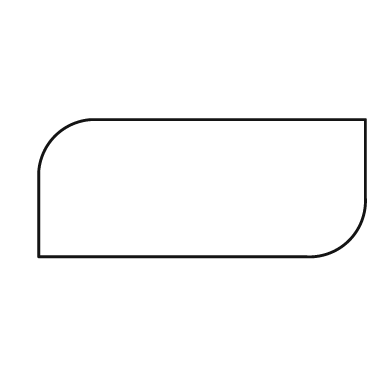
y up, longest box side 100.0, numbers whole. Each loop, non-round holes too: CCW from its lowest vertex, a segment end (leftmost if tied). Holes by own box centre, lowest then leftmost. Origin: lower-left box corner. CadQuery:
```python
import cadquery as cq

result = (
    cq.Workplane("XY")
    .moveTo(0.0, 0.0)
    .lineTo(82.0, 0.0)
    .threePointArc((95.0, 5.0), (100.0, 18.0))
    .lineTo(100.0, 42.0)
    .lineTo(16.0, 42.0)
    .threePointArc((5.0, 37.0), (0.0, 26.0))
    .close()
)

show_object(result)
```